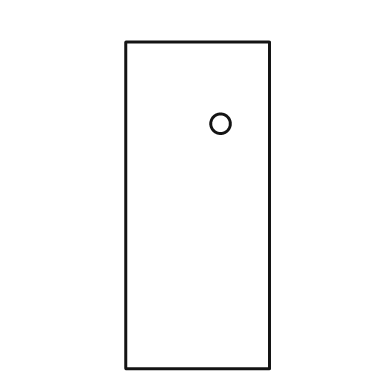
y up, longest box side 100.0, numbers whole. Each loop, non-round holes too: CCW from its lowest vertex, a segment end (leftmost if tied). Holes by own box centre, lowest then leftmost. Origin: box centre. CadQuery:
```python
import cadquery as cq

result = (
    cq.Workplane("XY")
    .moveTo(-22.0, -50.0)
    .lineTo(22.0, -50.0)
    .lineTo(22.0, 50.0)
    .lineTo(-22.0, 50.0)
    .close()
    .moveTo(7.0, 25.0)
    .circle(3.0)
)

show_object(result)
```